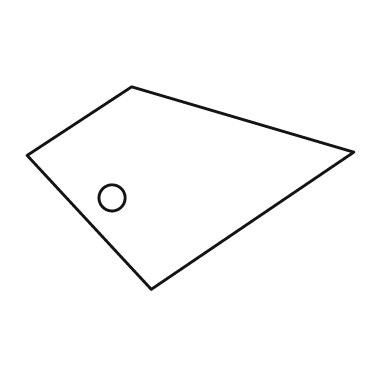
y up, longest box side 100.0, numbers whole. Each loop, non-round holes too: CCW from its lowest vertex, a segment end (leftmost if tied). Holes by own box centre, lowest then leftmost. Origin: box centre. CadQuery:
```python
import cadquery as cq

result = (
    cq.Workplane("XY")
    .moveTo(-12.0, -31.0)
    .lineTo(50.0, 11.0)
    .lineTo(-18.0, 31.0)
    .lineTo(-50.0, 10.0)
    .close()
    .moveTo(-24.0, -3.0)
    .circle(4.0)
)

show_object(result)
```